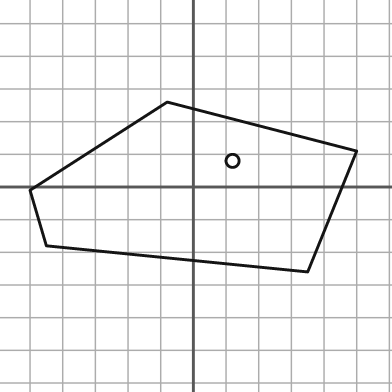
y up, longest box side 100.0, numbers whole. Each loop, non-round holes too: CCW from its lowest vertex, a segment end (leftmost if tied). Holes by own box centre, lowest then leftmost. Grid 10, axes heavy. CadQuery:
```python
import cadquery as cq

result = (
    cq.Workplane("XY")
    .moveTo(35.0, -26.0)
    .lineTo(50.0, 11.0)
    .lineTo(-8.0, 26.0)
    .lineTo(-50.0, -1.0)
    .lineTo(-45.0, -18.0)
    .close()
    .moveTo(12.0, 8.0)
    .circle(2.0)
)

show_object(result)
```